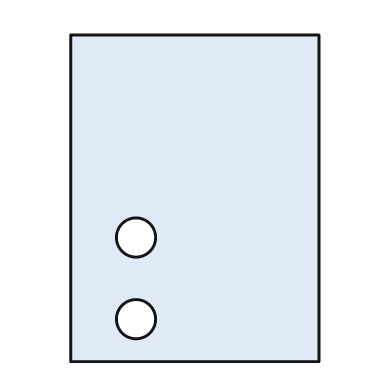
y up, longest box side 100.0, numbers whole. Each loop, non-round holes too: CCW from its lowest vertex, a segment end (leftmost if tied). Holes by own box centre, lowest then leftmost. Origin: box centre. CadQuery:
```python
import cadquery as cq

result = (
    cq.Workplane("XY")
    .moveTo(-38.0, -50.0)
    .lineTo(38.0, -50.0)
    .lineTo(38.0, 50.0)
    .lineTo(-38.0, 50.0)
    .close()
    .moveTo(-18.0, -37.0)
    .circle(6.0)
    .moveTo(-18.0, -12.0)
    .circle(6.0)
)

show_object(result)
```